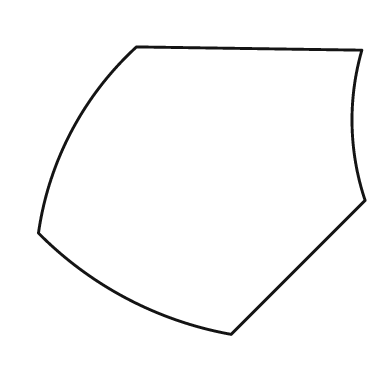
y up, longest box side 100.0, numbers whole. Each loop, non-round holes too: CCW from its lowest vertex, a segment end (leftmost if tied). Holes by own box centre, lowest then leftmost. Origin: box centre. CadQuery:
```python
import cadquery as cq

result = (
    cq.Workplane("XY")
    .moveTo(9.0, -44.0)
    .lineTo(50.0, -3.0)
    .threePointArc((46.0, 20.0), (49.0, 43.0))
    .lineTo(-20.0, 44.0)
    .threePointArc((-40.0, 18.0), (-50.0, -13.0))
    .threePointArc((-23.0, -33.0), (9.0, -44.0))
    .close()
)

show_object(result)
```